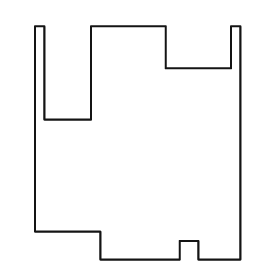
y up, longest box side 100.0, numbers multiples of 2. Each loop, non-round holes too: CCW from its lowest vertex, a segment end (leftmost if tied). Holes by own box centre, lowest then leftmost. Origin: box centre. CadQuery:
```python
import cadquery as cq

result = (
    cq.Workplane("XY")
    .moveTo(-16.0, -50.0)
    .lineTo(18.0, -50.0)
    .lineTo(18.0, -42.0)
    .lineTo(26.0, -42.0)
    .lineTo(26.0, -50.0)
    .lineTo(44.0, -50.0)
    .lineTo(44.0, 50.0)
    .lineTo(40.0, 50.0)
    .lineTo(40.0, 32.0)
    .lineTo(12.0, 32.0)
    .lineTo(12.0, 50.0)
    .lineTo(-20.0, 50.0)
    .lineTo(-20.0, 10.0)
    .lineTo(-40.0, 10.0)
    .lineTo(-40.0, 50.0)
    .lineTo(-44.0, 50.0)
    .lineTo(-44.0, -38.0)
    .lineTo(-16.0, -38.0)
    .close()
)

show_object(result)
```